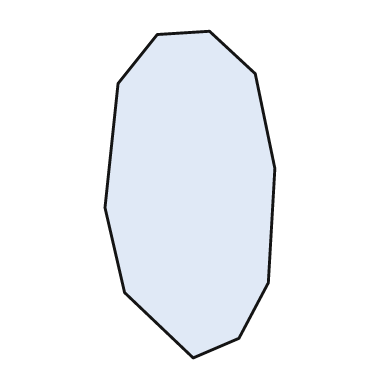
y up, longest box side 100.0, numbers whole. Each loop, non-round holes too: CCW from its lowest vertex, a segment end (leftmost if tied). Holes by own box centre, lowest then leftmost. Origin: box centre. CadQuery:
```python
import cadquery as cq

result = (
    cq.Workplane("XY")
    .moveTo(1.0, -50.0)
    .lineTo(15.0, -44.0)
    .lineTo(24.0, -27.0)
    .lineTo(26.0, 8.0)
    .lineTo(20.0, 37.0)
    .lineTo(6.0, 50.0)
    .lineTo(-10.0, 49.0)
    .lineTo(-22.0, 34.0)
    .lineTo(-26.0, -4.0)
    .lineTo(-20.0, -30.0)
    .close()
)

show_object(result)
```